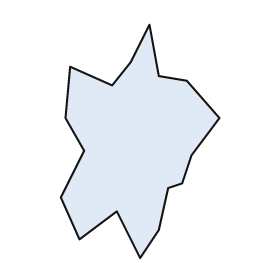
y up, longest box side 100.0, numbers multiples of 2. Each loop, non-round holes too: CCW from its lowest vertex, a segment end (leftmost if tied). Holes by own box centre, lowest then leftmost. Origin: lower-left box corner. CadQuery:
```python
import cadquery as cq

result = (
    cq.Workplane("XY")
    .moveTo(34.0, 0.0)
    .lineTo(42.0, 12.0)
    .lineTo(46.0, 30.0)
    .lineTo(52.0, 32.0)
    .lineTo(56.0, 44.0)
    .lineTo(68.0, 60.0)
    .lineTo(54.0, 76.0)
    .lineTo(42.0, 78.0)
    .lineTo(38.0, 100.0)
    .lineTo(30.0, 84.0)
    .lineTo(22.0, 74.0)
    .lineTo(4.0, 82.0)
    .lineTo(2.0, 60.0)
    .lineTo(10.0, 46.0)
    .lineTo(0.0, 26.0)
    .lineTo(8.0, 8.0)
    .lineTo(24.0, 20.0)
    .close()
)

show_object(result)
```